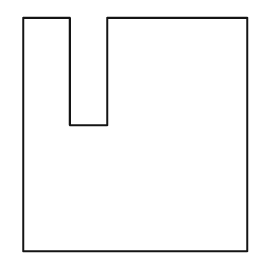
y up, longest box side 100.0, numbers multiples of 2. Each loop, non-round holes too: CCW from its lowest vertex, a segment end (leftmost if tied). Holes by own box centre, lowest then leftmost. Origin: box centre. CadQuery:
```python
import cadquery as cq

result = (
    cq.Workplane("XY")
    .moveTo(-48.0, -50.0)
    .lineTo(48.0, -50.0)
    .lineTo(48.0, 50.0)
    .lineTo(-12.0, 50.0)
    .lineTo(-12.0, 4.0)
    .lineTo(-28.0, 4.0)
    .lineTo(-28.0, 50.0)
    .lineTo(-48.0, 50.0)
    .close()
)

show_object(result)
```